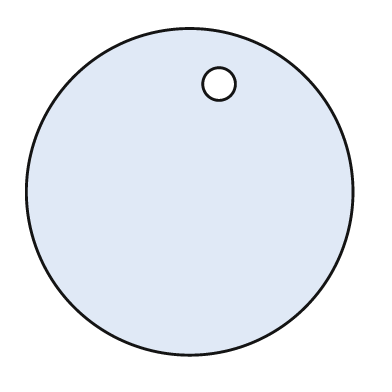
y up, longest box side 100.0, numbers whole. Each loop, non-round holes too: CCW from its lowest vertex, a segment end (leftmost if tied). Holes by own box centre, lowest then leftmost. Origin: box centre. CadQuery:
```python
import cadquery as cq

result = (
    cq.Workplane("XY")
    .moveTo(0.0, 0.0)
    .circle(50.0)
    .moveTo(9.0, 33.0)
    .circle(5.0)
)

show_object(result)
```